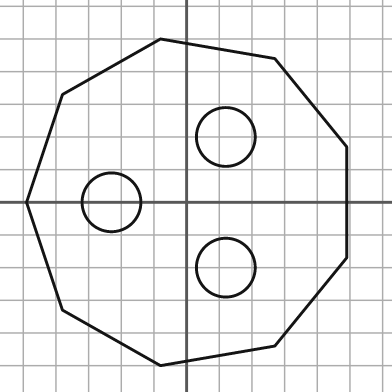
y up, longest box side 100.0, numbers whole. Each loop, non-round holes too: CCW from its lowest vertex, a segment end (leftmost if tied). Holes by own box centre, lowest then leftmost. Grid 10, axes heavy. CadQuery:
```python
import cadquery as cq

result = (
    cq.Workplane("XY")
    .moveTo(-8.0, -50.0)
    .lineTo(27.0, -44.0)
    .lineTo(49.0, -17.0)
    .lineTo(49.0, 17.0)
    .lineTo(27.0, 44.0)
    .lineTo(-8.0, 50.0)
    .lineTo(-38.0, 33.0)
    .lineTo(-49.0, 0.0)
    .lineTo(-38.0, -33.0)
    .close()
    .moveTo(12.0, -20.0)
    .circle(9.0)
    .moveTo(-23.0, 0.0)
    .circle(9.0)
    .moveTo(12.0, 20.0)
    .circle(9.0)
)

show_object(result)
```